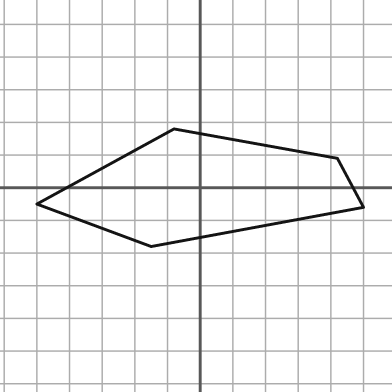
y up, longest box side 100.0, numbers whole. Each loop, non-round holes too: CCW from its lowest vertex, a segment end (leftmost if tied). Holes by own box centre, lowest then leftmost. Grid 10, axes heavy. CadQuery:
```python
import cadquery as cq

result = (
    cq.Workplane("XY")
    .moveTo(-15.0, -18.0)
    .lineTo(50.0, -6.0)
    .lineTo(42.0, 9.0)
    .lineTo(-8.0, 18.0)
    .lineTo(-50.0, -5.0)
    .close()
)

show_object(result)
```